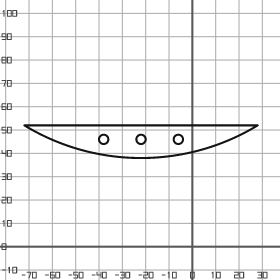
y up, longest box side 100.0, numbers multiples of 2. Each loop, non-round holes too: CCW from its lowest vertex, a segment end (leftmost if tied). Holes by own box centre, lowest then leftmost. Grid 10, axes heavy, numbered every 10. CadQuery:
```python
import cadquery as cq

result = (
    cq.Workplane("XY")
    .moveTo(-72.0, 52.0)
    .threePointArc((-22.0, 38.0), (28.0, 52.0))
    .close()
    .moveTo(-38.0, 46.0)
    .circle(2.0)
    .moveTo(-22.0, 46.0)
    .circle(2.0)
    .moveTo(-6.0, 46.0)
    .circle(2.0)
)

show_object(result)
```